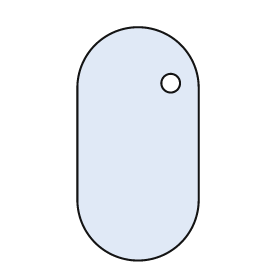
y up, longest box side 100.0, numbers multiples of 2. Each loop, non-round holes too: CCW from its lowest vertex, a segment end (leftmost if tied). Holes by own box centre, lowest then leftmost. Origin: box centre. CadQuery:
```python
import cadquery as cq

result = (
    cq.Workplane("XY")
    .moveTo(-26.0, -24.0)
    .threePointArc((0.0, -50.0), (26.0, -24.0))
    .lineTo(26.0, 24.0)
    .threePointArc((0.0, 50.0), (-26.0, 24.0))
    .close()
    .moveTo(14.0, 26.0)
    .circle(4.0)
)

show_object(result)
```